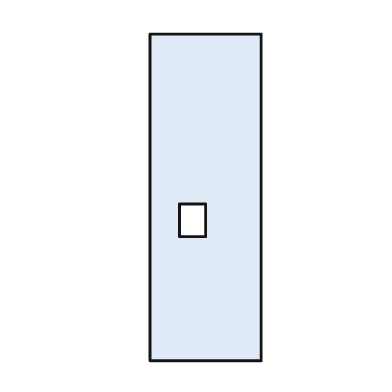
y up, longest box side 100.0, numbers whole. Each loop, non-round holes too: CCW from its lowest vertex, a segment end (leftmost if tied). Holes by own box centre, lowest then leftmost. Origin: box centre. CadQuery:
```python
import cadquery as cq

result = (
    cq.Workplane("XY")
    .moveTo(-17.0, -50.0)
    .lineTo(17.0, -50.0)
    .lineTo(17.0, 50.0)
    .lineTo(-17.0, 50.0)
    .close()
    .moveTo(-8.0, -12.0)
    .lineTo(0.0, -12.0)
    .lineTo(0.0, -2.0)
    .lineTo(-8.0, -2.0)
    .close()
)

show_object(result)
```